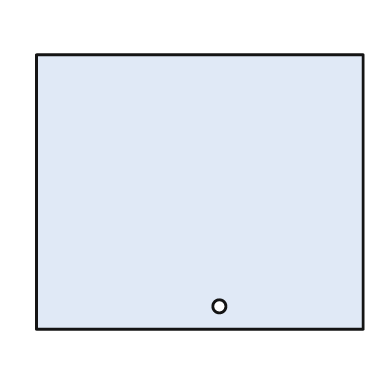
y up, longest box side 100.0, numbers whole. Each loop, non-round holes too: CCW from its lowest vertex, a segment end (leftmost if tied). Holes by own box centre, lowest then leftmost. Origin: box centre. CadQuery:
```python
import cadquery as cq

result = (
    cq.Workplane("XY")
    .moveTo(-50.0, -42.0)
    .lineTo(50.0, -42.0)
    .lineTo(50.0, 42.0)
    .lineTo(-50.0, 42.0)
    .close()
    .moveTo(6.0, -35.0)
    .circle(2.0)
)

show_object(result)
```